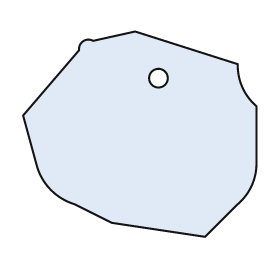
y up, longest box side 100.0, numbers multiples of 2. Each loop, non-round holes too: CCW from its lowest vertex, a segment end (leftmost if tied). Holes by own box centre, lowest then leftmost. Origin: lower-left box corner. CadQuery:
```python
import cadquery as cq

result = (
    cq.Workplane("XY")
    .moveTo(78.0, 0.0)
    .lineTo(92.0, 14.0)
    .threePointArc((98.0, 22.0), (100.0, 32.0))
    .lineTo(100.0, 56.0)
    .threePointArc((94.0, 64.0), (92.0, 74.0))
    .lineTo(48.0, 88.0)
    .lineTo(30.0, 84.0)
    .threePointArc((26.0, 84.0), (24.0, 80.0))
    .lineTo(0.0, 52.0)
    .lineTo(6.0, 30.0)
    .threePointArc((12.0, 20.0), (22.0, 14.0))
    .lineTo(38.0, 6.0)
    .close()
    .moveTo(58.0, 68.0)
    .circle(4.0)
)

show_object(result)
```